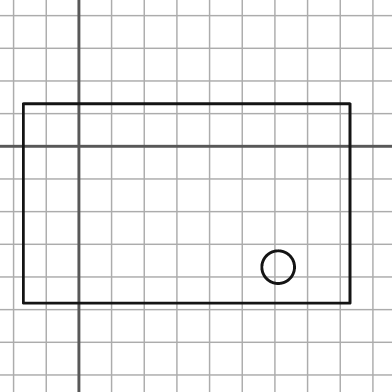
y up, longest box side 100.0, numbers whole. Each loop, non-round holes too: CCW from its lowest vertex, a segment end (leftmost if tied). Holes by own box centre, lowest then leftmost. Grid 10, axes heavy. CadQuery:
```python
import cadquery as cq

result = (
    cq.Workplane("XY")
    .moveTo(-17.0, -48.0)
    .lineTo(83.0, -48.0)
    .lineTo(83.0, 13.0)
    .lineTo(-17.0, 13.0)
    .close()
    .moveTo(61.0, -37.0)
    .circle(5.0)
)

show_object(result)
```